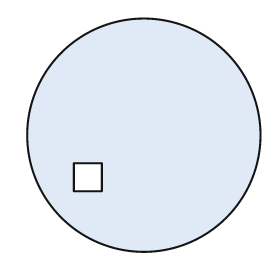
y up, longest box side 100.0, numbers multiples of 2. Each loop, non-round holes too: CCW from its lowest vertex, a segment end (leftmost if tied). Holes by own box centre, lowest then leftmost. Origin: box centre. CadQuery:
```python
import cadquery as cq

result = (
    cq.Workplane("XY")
    .moveTo(0.0, 0.0)
    .circle(50.0)
    .moveTo(-30.0, -24.0)
    .lineTo(-18.0, -24.0)
    .lineTo(-18.0, -12.0)
    .lineTo(-30.0, -12.0)
    .close()
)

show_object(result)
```